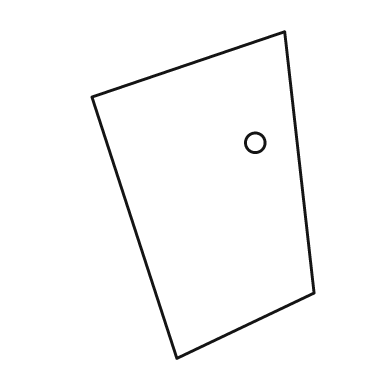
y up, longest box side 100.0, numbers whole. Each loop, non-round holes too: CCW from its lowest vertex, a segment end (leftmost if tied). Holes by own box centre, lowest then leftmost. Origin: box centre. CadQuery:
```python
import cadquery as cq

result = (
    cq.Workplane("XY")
    .moveTo(-8.0, -50.0)
    .lineTo(34.0, -30.0)
    .lineTo(25.0, 50.0)
    .lineTo(-34.0, 30.0)
    .close()
    .moveTo(16.0, 16.0)
    .circle(3.0)
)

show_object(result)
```